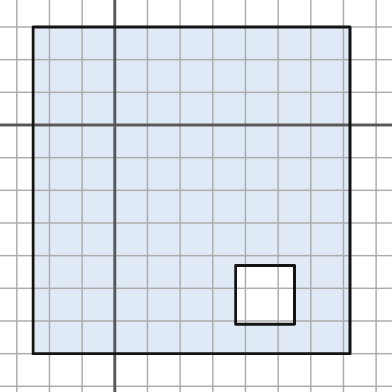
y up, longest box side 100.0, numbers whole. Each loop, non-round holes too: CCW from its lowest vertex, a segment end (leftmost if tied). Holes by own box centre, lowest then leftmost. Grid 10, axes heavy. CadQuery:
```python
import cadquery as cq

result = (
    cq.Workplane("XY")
    .moveTo(-25.0, -70.0)
    .lineTo(72.0, -70.0)
    .lineTo(72.0, 30.0)
    .lineTo(-25.0, 30.0)
    .close()
    .moveTo(37.0, -61.0)
    .lineTo(55.0, -61.0)
    .lineTo(55.0, -43.0)
    .lineTo(37.0, -43.0)
    .close()
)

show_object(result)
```